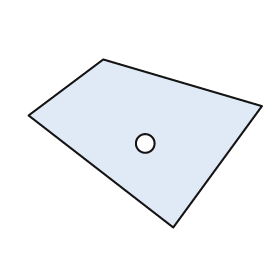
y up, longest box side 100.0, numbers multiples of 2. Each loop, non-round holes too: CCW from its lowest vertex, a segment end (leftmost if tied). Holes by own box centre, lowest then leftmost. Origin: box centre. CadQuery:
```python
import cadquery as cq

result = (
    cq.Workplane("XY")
    .moveTo(12.0, -36.0)
    .lineTo(50.0, 16.0)
    .lineTo(-18.0, 36.0)
    .lineTo(-50.0, 12.0)
    .close()
    .moveTo(0.0, 0.0)
    .circle(4.0)
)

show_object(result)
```